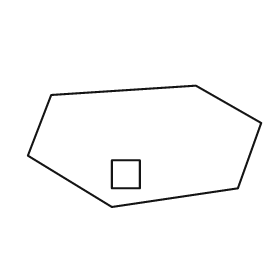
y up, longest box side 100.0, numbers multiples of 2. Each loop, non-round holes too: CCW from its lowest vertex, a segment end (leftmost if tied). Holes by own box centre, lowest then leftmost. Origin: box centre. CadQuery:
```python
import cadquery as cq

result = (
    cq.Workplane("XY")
    .moveTo(-14.0, -26.0)
    .lineTo(40.0, -18.0)
    .lineTo(50.0, 10.0)
    .lineTo(22.0, 26.0)
    .lineTo(-40.0, 22.0)
    .lineTo(-50.0, -4.0)
    .close()
    .moveTo(-14.0, -18.0)
    .lineTo(-2.0, -18.0)
    .lineTo(-2.0, -6.0)
    .lineTo(-14.0, -6.0)
    .close()
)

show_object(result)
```